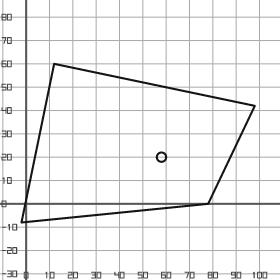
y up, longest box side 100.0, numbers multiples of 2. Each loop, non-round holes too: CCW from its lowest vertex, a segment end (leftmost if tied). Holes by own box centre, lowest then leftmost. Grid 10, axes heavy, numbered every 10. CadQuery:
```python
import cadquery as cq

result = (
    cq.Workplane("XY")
    .moveTo(-2.0, -8.0)
    .lineTo(78.0, 0.0)
    .lineTo(98.0, 42.0)
    .lineTo(12.0, 60.0)
    .close()
    .moveTo(58.0, 20.0)
    .circle(2.0)
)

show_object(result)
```